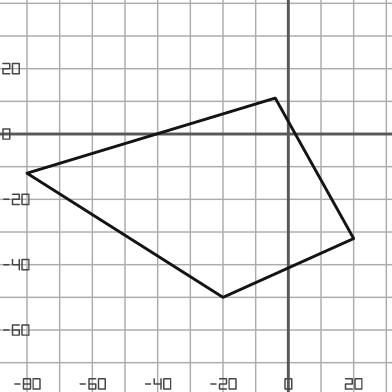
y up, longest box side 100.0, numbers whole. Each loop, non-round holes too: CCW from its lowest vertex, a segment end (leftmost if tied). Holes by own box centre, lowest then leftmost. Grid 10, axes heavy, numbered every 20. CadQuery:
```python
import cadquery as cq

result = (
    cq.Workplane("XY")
    .moveTo(-20.0, -50.0)
    .lineTo(20.0, -32.0)
    .lineTo(-4.0, 11.0)
    .lineTo(-80.0, -12.0)
    .close()
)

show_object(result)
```